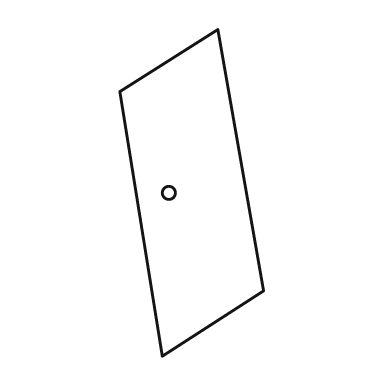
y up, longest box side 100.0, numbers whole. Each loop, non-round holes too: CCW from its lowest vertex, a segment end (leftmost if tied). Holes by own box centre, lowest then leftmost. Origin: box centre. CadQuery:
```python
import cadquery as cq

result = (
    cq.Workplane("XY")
    .moveTo(-9.0, -50.0)
    .lineTo(22.0, -30.0)
    .lineTo(8.0, 50.0)
    .lineTo(-22.0, 31.0)
    .close()
    .moveTo(-7.0, 0.0)
    .circle(2.0)
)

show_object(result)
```